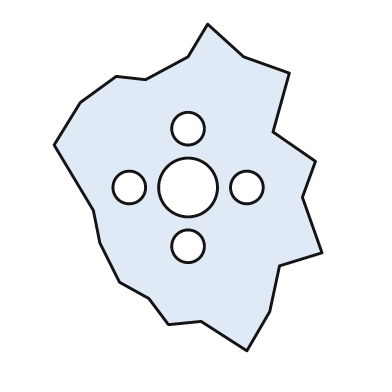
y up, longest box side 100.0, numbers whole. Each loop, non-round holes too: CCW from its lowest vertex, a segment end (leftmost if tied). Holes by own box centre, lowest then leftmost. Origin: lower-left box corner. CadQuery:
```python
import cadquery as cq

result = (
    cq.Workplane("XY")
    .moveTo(59.0, 0.0)
    .lineTo(66.0, 12.0)
    .lineTo(69.0, 26.0)
    .lineTo(82.0, 30.0)
    .lineTo(76.0, 47.0)
    .lineTo(80.0, 58.0)
    .lineTo(67.0, 67.0)
    .lineTo(72.0, 85.0)
    .lineTo(58.0, 90.0)
    .lineTo(47.0, 100.0)
    .lineTo(41.0, 90.0)
    .lineTo(28.0, 83.0)
    .lineTo(19.0, 84.0)
    .lineTo(8.0, 76.0)
    .lineTo(0.0, 63.0)
    .lineTo(12.0, 43.0)
    .lineTo(14.0, 33.0)
    .lineTo(20.0, 21.0)
    .lineTo(29.0, 16.0)
    .lineTo(35.0, 8.0)
    .lineTo(45.0, 9.0)
    .close()
    .moveTo(41.0, 32.0)
    .circle(5.0)
    .moveTo(23.0, 50.0)
    .circle(5.0)
    .moveTo(41.0, 50.0)
    .circle(9.0)
    .moveTo(59.0, 50.0)
    .circle(5.0)
    .moveTo(41.0, 68.0)
    .circle(5.0)
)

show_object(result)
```